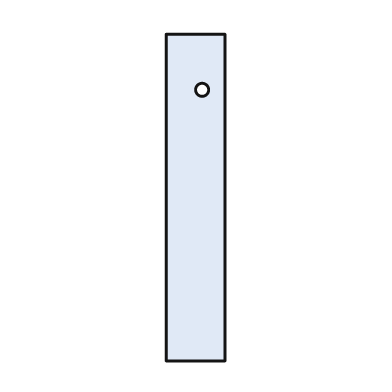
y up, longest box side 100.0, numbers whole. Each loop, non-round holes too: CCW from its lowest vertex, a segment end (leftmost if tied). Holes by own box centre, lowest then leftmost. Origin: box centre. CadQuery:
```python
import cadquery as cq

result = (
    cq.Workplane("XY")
    .moveTo(-9.0, -50.0)
    .lineTo(9.0, -50.0)
    .lineTo(9.0, 50.0)
    .lineTo(-9.0, 50.0)
    .close()
    .moveTo(2.0, 33.0)
    .circle(2.0)
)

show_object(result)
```